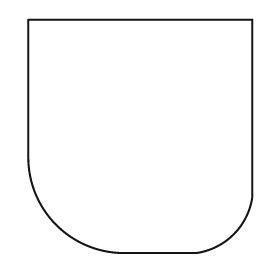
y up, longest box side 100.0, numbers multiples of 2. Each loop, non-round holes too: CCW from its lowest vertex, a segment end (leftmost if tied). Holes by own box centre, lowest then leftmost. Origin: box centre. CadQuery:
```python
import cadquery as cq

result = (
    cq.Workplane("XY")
    .moveTo(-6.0, -50.0)
    .lineTo(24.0, -50.0)
    .threePointArc((40.0, -42.0), (48.0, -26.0))
    .lineTo(48.0, 50.0)
    .lineTo(-48.0, 50.0)
    .lineTo(-48.0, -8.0)
    .threePointArc((-36.0, -38.0), (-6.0, -50.0))
    .close()
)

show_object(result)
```